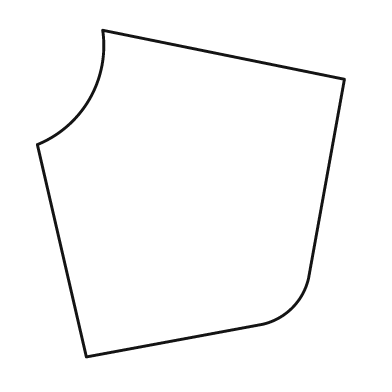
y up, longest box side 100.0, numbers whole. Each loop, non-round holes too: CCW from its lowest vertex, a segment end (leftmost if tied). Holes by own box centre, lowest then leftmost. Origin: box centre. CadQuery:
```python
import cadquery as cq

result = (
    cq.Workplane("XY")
    .moveTo(-32.0, -50.0)
    .lineTo(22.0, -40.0)
    .threePointArc((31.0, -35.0), (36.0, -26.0))
    .lineTo(47.0, 35.0)
    .lineTo(-27.0, 50.0)
    .threePointArc((-31.0, 29.0), (-47.0, 15.0))
    .close()
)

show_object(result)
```